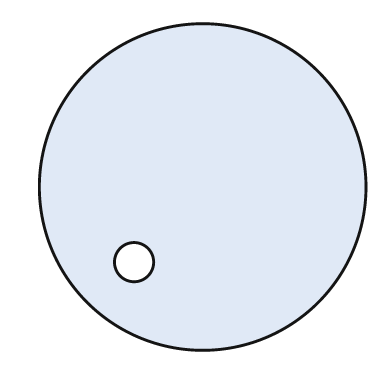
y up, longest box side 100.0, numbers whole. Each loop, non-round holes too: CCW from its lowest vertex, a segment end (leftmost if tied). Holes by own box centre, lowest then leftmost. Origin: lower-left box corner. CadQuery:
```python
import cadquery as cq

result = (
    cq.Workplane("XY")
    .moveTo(50.0, 50.0)
    .circle(50.0)
    .moveTo(29.0, 27.0)
    .circle(6.0)
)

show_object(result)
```